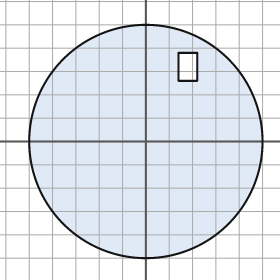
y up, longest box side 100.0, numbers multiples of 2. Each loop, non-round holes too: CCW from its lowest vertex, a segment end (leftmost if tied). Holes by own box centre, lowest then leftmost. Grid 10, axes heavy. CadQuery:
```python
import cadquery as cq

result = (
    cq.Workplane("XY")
    .moveTo(0.0, 0.0)
    .circle(50.0)
    .moveTo(14.0, 26.0)
    .lineTo(22.0, 26.0)
    .lineTo(22.0, 38.0)
    .lineTo(14.0, 38.0)
    .close()
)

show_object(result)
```